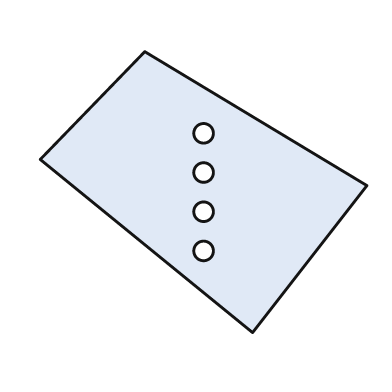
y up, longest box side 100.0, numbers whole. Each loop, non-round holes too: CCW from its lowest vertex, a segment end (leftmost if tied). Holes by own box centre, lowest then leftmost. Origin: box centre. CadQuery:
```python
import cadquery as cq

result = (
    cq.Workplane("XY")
    .moveTo(15.0, -43.0)
    .lineTo(50.0, 2.0)
    .lineTo(-18.0, 43.0)
    .lineTo(-50.0, 10.0)
    .close()
    .moveTo(0.0, -18.0)
    .circle(3.0)
    .moveTo(0.0, -6.0)
    .circle(3.0)
    .moveTo(0.0, 6.0)
    .circle(3.0)
    .moveTo(0.0, 18.0)
    .circle(3.0)
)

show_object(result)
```